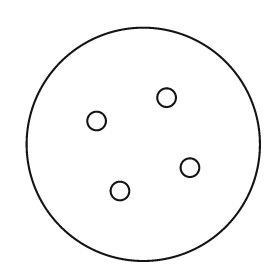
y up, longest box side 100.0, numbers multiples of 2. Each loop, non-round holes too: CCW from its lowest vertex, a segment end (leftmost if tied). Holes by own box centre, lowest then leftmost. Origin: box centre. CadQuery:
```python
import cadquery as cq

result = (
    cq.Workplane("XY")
    .moveTo(0.0, 0.0)
    .circle(50.0)
    .moveTo(-10.0, -20.0)
    .circle(4.0)
    .moveTo(20.0, -10.0)
    .circle(4.0)
    .moveTo(-20.0, 10.0)
    .circle(4.0)
    .moveTo(10.0, 20.0)
    .circle(4.0)
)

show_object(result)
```